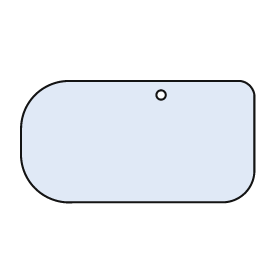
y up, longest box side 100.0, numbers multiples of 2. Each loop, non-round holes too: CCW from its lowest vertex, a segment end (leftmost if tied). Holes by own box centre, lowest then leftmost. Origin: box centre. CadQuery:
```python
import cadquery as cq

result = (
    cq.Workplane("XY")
    .moveTo(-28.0, -26.0)
    .lineTo(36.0, -26.0)
    .threePointArc((46.0, -22.0), (50.0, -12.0))
    .lineTo(50.0, 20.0)
    .threePointArc((48.0, 24.0), (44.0, 26.0))
    .lineTo(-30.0, 26.0)
    .threePointArc((-44.0, 20.0), (-50.0, 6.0))
    .lineTo(-50.0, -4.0)
    .threePointArc((-44.0, -20.0), (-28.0, -26.0))
    .close()
    .moveTo(10.0, 20.0)
    .circle(2.0)
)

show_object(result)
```